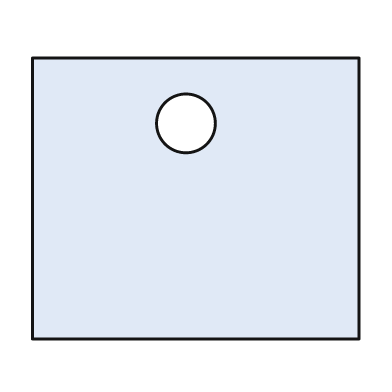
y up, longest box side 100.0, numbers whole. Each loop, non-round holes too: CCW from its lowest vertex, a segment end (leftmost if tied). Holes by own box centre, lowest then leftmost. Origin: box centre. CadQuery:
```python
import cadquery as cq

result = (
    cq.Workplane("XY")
    .moveTo(-50.0, -43.0)
    .lineTo(50.0, -43.0)
    .lineTo(50.0, 43.0)
    .lineTo(-50.0, 43.0)
    .close()
    .moveTo(-3.0, 23.0)
    .circle(9.0)
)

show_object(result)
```